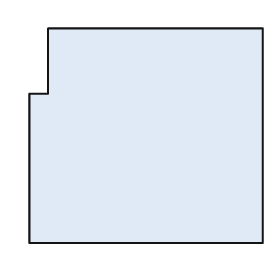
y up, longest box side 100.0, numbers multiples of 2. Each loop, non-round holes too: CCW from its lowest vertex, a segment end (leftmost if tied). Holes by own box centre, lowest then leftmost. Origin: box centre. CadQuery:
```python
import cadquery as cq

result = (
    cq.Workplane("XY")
    .moveTo(-50.0, -46.0)
    .lineTo(50.0, -46.0)
    .lineTo(50.0, 46.0)
    .lineTo(-42.0, 46.0)
    .lineTo(-42.0, 18.0)
    .lineTo(-50.0, 18.0)
    .close()
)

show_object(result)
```